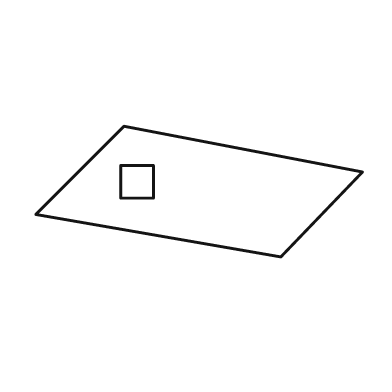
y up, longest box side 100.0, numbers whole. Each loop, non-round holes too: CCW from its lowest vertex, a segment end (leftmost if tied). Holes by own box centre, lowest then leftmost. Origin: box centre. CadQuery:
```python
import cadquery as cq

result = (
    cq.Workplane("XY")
    .moveTo(25.0, -20.0)
    .lineTo(50.0, 6.0)
    .lineTo(-23.0, 20.0)
    .lineTo(-50.0, -7.0)
    .close()
    .moveTo(-24.0, -2.0)
    .lineTo(-14.0, -2.0)
    .lineTo(-14.0, 8.0)
    .lineTo(-24.0, 8.0)
    .close()
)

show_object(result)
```